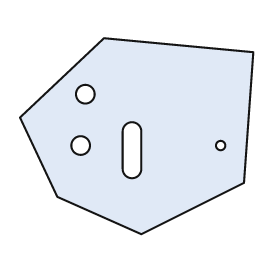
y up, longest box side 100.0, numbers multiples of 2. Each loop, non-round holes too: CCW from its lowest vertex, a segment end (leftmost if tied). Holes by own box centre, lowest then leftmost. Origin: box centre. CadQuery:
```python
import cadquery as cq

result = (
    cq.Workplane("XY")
    .moveTo(2.0, -42.0)
    .lineTo(46.0, -20.0)
    .lineTo(50.0, 36.0)
    .lineTo(-14.0, 42.0)
    .lineTo(-50.0, 8.0)
    .lineTo(-34.0, -26.0)
    .close()
    .moveTo(-6.0, -14.0)
    .threePointArc((-2.0, -18.0), (2.0, -14.0))
    .lineTo(2.0, 2.0)
    .threePointArc((-2.0, 6.0), (-6.0, 2.0))
    .close()
    .moveTo(-24.0, -4.0)
    .circle(4.0)
    .moveTo(36.0, -4.0)
    .circle(2.0)
    .moveTo(-22.0, 18.0)
    .circle(4.0)
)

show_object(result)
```